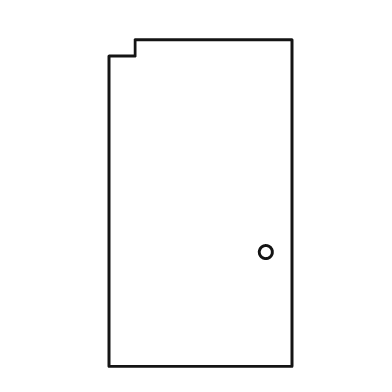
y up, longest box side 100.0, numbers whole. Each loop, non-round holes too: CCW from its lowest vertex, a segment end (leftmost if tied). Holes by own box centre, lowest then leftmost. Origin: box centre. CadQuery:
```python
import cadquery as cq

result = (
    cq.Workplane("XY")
    .moveTo(-28.0, -50.0)
    .lineTo(28.0, -50.0)
    .lineTo(28.0, 50.0)
    .lineTo(-20.0, 50.0)
    .lineTo(-20.0, 45.0)
    .lineTo(-28.0, 45.0)
    .close()
    .moveTo(20.0, -15.0)
    .circle(2.0)
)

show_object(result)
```